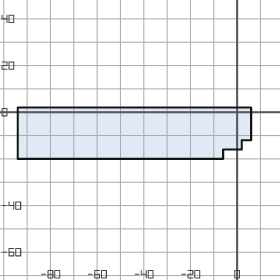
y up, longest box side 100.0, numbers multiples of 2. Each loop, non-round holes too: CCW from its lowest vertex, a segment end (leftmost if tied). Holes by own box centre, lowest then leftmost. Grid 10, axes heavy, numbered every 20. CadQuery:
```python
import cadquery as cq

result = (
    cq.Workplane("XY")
    .moveTo(-94.0, -20.0)
    .lineTo(-6.0, -20.0)
    .lineTo(-6.0, -16.0)
    .lineTo(2.0, -16.0)
    .lineTo(2.0, -12.0)
    .lineTo(6.0, -12.0)
    .lineTo(6.0, 2.0)
    .lineTo(-94.0, 2.0)
    .close()
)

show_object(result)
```